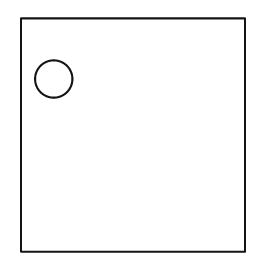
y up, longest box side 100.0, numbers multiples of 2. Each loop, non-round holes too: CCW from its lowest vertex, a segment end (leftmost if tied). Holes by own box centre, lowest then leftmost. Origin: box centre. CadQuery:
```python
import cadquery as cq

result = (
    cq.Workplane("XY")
    .moveTo(-48.0, -50.0)
    .lineTo(48.0, -50.0)
    .lineTo(48.0, 50.0)
    .lineTo(-48.0, 50.0)
    .close()
    .moveTo(-34.0, 24.0)
    .circle(8.0)
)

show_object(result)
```